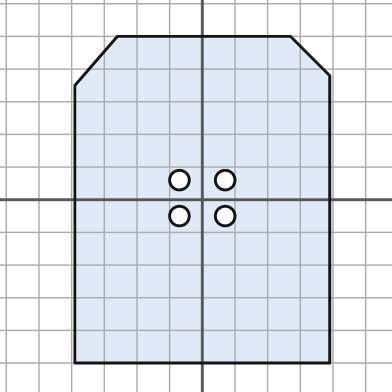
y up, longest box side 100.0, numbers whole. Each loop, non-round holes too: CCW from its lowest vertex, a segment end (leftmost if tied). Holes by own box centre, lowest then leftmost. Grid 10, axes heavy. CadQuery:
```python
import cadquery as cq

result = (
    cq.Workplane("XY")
    .moveTo(-39.0, -50.0)
    .lineTo(39.0, -50.0)
    .lineTo(39.0, 38.0)
    .lineTo(27.0, 50.0)
    .lineTo(-26.0, 50.0)
    .lineTo(-39.0, 35.0)
    .close()
    .moveTo(-7.0, -5.0)
    .circle(3.0)
    .moveTo(7.0, -5.0)
    .circle(3.0)
    .moveTo(-7.0, 6.0)
    .circle(3.0)
    .moveTo(7.0, 6.0)
    .circle(3.0)
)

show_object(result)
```